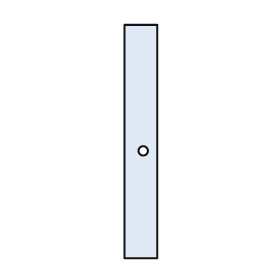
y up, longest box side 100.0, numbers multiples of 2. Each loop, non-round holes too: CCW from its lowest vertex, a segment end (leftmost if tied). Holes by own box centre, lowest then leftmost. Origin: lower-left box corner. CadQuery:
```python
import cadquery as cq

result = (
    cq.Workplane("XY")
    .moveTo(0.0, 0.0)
    .lineTo(14.0, 0.0)
    .lineTo(14.0, 100.0)
    .lineTo(0.0, 100.0)
    .close()
    .moveTo(8.0, 46.0)
    .circle(2.0)
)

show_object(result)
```